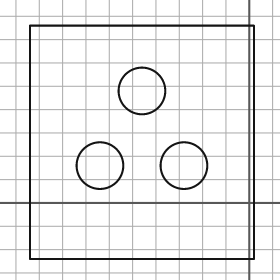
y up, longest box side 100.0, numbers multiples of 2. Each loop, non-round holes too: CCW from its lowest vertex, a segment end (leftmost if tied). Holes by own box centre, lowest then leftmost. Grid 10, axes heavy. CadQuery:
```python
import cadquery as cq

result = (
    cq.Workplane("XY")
    .moveTo(-94.0, -24.0)
    .lineTo(2.0, -24.0)
    .lineTo(2.0, 76.0)
    .lineTo(-94.0, 76.0)
    .close()
    .moveTo(-64.0, 16.0)
    .circle(10.0)
    .moveTo(-28.0, 16.0)
    .circle(10.0)
    .moveTo(-46.0, 48.0)
    .circle(10.0)
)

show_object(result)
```